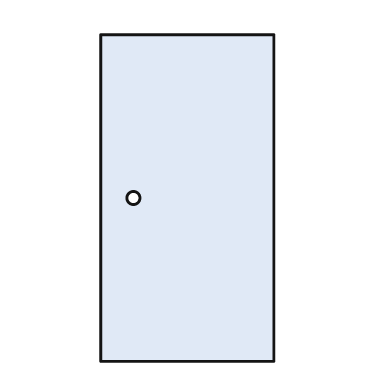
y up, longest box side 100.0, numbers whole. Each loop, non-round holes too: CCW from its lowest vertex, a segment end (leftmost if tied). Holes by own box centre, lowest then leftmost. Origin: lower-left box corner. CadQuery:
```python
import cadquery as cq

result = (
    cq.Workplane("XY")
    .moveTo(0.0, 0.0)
    .lineTo(53.0, 0.0)
    .lineTo(53.0, 100.0)
    .lineTo(0.0, 100.0)
    .close()
    .moveTo(10.0, 50.0)
    .circle(2.0)
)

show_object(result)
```